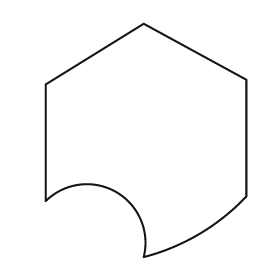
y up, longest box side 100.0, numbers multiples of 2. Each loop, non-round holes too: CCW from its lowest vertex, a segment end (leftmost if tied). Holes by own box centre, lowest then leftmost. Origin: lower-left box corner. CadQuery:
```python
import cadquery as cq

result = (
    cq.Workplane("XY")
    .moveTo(42.0, 0.0)
    .threePointArc((66.0, 10.0), (86.0, 26.0))
    .lineTo(86.0, 76.0)
    .lineTo(42.0, 100.0)
    .lineTo(0.0, 74.0)
    .lineTo(0.0, 24.0)
    .threePointArc((30.0, 28.0), (42.0, 0.0))
    .close()
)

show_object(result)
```